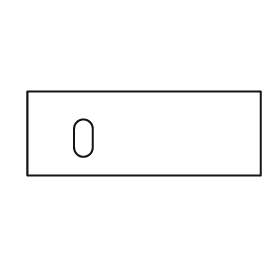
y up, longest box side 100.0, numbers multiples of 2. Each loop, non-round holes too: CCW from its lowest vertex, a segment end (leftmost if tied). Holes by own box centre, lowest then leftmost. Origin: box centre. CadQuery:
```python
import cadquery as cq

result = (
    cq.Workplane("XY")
    .moveTo(-50.0, -18.0)
    .lineTo(50.0, -18.0)
    .lineTo(50.0, 18.0)
    .lineTo(-50.0, 18.0)
    .close()
    .moveTo(-30.0, -6.0)
    .threePointArc((-26.0, -10.0), (-22.0, -6.0))
    .lineTo(-22.0, 2.0)
    .threePointArc((-26.0, 6.0), (-30.0, 2.0))
    .close()
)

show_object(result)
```